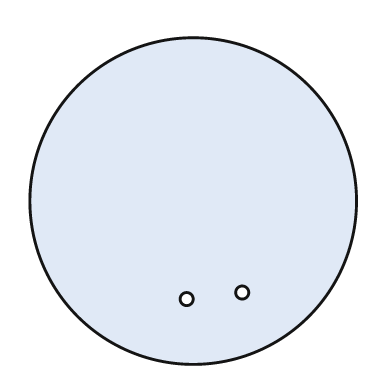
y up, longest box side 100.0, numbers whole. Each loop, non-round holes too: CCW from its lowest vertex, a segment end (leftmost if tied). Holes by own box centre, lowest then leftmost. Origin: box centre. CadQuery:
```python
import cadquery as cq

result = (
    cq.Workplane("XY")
    .moveTo(0.0, 0.0)
    .circle(50.0)
    .moveTo(-2.0, -30.0)
    .circle(2.0)
    .moveTo(15.0, -28.0)
    .circle(2.0)
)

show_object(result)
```